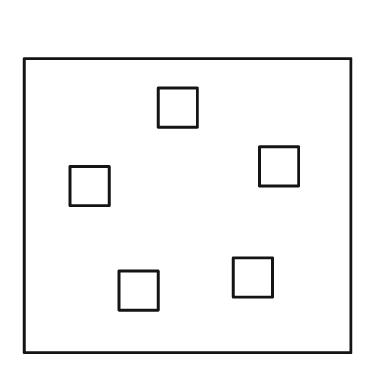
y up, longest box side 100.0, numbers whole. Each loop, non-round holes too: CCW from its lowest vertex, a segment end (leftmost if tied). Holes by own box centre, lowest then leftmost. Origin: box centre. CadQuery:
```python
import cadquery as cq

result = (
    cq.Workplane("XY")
    .moveTo(-50.0, -45.0)
    .lineTo(50.0, -45.0)
    .lineTo(50.0, 45.0)
    .lineTo(-50.0, 45.0)
    .close()
    .moveTo(-21.0, -32.0)
    .lineTo(-9.0, -32.0)
    .lineTo(-9.0, -20.0)
    .lineTo(-21.0, -20.0)
    .close()
    .moveTo(14.0, -28.0)
    .lineTo(26.0, -28.0)
    .lineTo(26.0, -16.0)
    .lineTo(14.0, -16.0)
    .close()
    .moveTo(-36.0, 0.0)
    .lineTo(-24.0, 0.0)
    .lineTo(-24.0, 12.0)
    .lineTo(-36.0, 12.0)
    .close()
    .moveTo(22.0, 6.0)
    .lineTo(34.0, 6.0)
    .lineTo(34.0, 18.0)
    .lineTo(22.0, 18.0)
    .close()
    .moveTo(-9.0, 24.0)
    .lineTo(3.0, 24.0)
    .lineTo(3.0, 36.0)
    .lineTo(-9.0, 36.0)
    .close()
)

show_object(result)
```